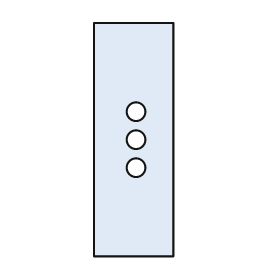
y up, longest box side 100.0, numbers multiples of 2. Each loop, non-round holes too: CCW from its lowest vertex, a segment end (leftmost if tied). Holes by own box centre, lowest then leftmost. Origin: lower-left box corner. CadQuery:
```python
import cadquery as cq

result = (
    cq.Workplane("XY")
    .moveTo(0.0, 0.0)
    .lineTo(34.0, 0.0)
    .lineTo(34.0, 100.0)
    .lineTo(0.0, 100.0)
    .close()
    .moveTo(18.0, 38.0)
    .circle(4.0)
    .moveTo(18.0, 50.0)
    .circle(4.0)
    .moveTo(18.0, 62.0)
    .circle(4.0)
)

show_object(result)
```